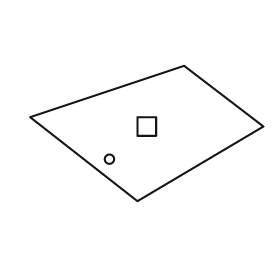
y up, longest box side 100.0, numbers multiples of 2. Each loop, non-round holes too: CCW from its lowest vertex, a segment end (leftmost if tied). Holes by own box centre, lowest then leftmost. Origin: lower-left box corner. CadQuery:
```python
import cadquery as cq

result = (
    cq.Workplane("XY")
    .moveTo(46.0, 0.0)
    .lineTo(100.0, 32.0)
    .lineTo(66.0, 58.0)
    .lineTo(0.0, 36.0)
    .close()
    .moveTo(34.0, 18.0)
    .circle(2.0)
    .moveTo(46.0, 28.0)
    .lineTo(54.0, 28.0)
    .lineTo(54.0, 36.0)
    .lineTo(46.0, 36.0)
    .close()
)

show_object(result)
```